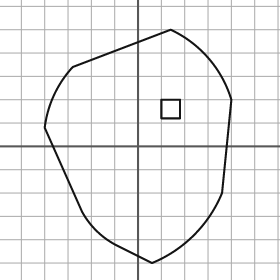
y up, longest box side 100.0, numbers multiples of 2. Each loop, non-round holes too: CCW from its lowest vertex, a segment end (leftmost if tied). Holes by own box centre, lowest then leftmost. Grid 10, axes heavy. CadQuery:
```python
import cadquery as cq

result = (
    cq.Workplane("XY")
    .moveTo(6.0, -50.0)
    .threePointArc((24.0, -38.0), (36.0, -20.0))
    .lineTo(40.0, 20.0)
    .threePointArc((30.0, 38.0), (14.0, 50.0))
    .lineTo(-28.0, 34.0)
    .threePointArc((-36.0, 22.0), (-40.0, 8.0))
    .lineTo(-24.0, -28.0)
    .threePointArc((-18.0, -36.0), (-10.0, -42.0))
    .close()
    .moveTo(10.0, 12.0)
    .lineTo(18.0, 12.0)
    .lineTo(18.0, 20.0)
    .lineTo(10.0, 20.0)
    .close()
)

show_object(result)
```